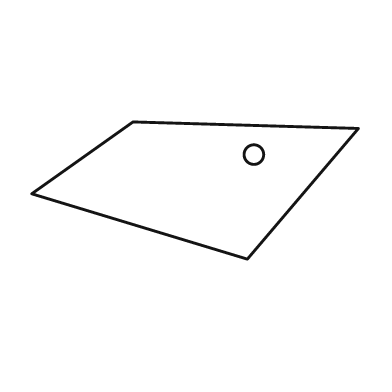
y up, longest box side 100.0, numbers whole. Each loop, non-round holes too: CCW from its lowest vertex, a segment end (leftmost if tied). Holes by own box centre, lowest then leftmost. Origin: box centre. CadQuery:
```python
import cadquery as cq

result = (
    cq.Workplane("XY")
    .moveTo(16.0, -21.0)
    .lineTo(50.0, 19.0)
    .lineTo(-19.0, 21.0)
    .lineTo(-50.0, -1.0)
    .close()
    .moveTo(18.0, 11.0)
    .circle(3.0)
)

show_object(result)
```